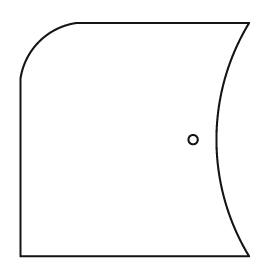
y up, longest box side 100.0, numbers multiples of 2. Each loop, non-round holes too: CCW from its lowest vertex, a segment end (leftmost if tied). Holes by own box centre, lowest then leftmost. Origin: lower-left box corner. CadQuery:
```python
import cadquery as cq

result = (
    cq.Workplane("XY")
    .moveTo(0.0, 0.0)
    .lineTo(98.0, 0.0)
    .threePointArc((84.0, 50.0), (98.0, 100.0))
    .lineTo(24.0, 100.0)
    .threePointArc((8.0, 92.0), (0.0, 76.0))
    .close()
    .moveTo(74.0, 50.0)
    .circle(2.0)
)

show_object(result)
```